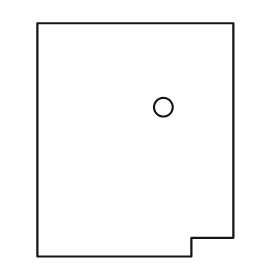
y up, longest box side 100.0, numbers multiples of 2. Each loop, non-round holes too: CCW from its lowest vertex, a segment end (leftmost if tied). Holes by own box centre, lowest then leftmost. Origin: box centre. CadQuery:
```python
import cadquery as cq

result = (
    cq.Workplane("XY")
    .moveTo(-42.0, -50.0)
    .lineTo(24.0, -50.0)
    .lineTo(24.0, -42.0)
    .lineTo(42.0, -42.0)
    .lineTo(42.0, 50.0)
    .lineTo(-42.0, 50.0)
    .close()
    .moveTo(12.0, 14.0)
    .circle(4.0)
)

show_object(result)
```